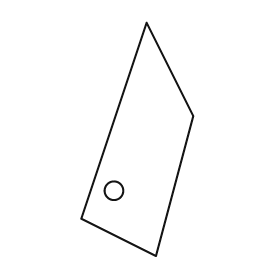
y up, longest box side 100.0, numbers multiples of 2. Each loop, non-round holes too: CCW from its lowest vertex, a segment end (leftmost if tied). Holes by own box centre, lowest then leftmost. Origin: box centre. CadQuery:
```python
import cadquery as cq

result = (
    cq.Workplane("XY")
    .moveTo(8.0, -50.0)
    .lineTo(24.0, 10.0)
    .lineTo(4.0, 50.0)
    .lineTo(-24.0, -34.0)
    .close()
    .moveTo(-10.0, -22.0)
    .circle(4.0)
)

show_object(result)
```